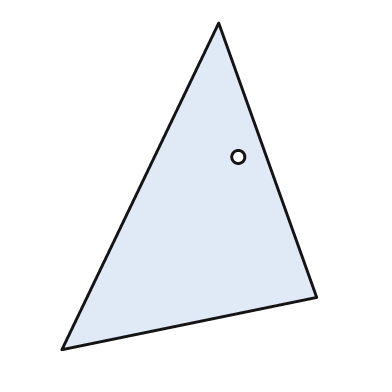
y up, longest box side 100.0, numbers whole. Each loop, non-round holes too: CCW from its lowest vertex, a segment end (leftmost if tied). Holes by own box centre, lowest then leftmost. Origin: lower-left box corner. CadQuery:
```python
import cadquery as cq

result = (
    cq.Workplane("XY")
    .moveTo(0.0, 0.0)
    .lineTo(78.0, 16.0)
    .lineTo(48.0, 100.0)
    .close()
    .moveTo(54.0, 59.0)
    .circle(2.0)
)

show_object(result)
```